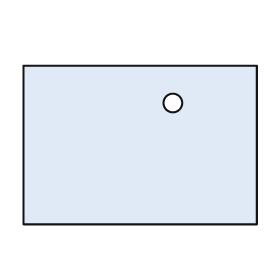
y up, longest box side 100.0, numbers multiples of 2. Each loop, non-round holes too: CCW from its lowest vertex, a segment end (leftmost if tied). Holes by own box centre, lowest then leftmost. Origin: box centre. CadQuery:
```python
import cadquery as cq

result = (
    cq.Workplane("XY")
    .moveTo(-50.0, -34.0)
    .lineTo(50.0, -34.0)
    .lineTo(50.0, 34.0)
    .lineTo(-50.0, 34.0)
    .close()
    .moveTo(14.0, 18.0)
    .circle(4.0)
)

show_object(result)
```